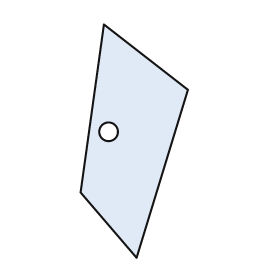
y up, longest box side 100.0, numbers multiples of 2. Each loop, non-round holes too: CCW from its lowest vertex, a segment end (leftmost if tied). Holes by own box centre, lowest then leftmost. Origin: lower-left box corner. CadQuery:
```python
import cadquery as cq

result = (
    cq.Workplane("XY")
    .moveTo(24.0, 0.0)
    .lineTo(46.0, 72.0)
    .lineTo(10.0, 100.0)
    .lineTo(0.0, 28.0)
    .close()
    .moveTo(12.0, 54.0)
    .circle(4.0)
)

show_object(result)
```